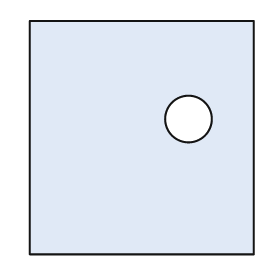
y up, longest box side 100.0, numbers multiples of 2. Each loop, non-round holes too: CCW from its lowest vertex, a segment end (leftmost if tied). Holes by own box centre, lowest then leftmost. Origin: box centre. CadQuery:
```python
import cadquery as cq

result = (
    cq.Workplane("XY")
    .moveTo(-48.0, -50.0)
    .lineTo(48.0, -50.0)
    .lineTo(48.0, 50.0)
    .lineTo(-48.0, 50.0)
    .close()
    .moveTo(20.0, 8.0)
    .circle(10.0)
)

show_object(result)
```